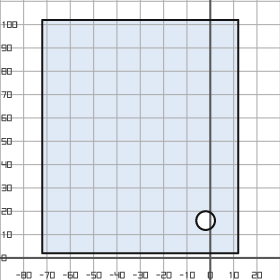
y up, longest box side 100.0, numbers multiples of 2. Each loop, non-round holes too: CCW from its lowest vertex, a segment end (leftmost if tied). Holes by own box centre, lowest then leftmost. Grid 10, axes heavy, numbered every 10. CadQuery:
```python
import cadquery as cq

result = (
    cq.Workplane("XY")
    .moveTo(-72.0, 2.0)
    .lineTo(12.0, 2.0)
    .lineTo(12.0, 102.0)
    .lineTo(-72.0, 102.0)
    .close()
    .moveTo(-2.0, 16.0)
    .circle(4.0)
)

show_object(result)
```